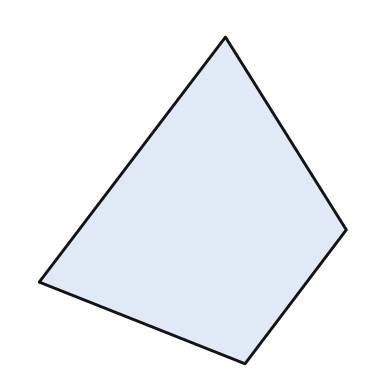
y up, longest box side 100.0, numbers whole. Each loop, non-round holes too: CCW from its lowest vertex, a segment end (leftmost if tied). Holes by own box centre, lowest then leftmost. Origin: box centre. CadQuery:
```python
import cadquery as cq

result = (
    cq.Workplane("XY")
    .moveTo(16.0, -50.0)
    .lineTo(47.0, -9.0)
    .lineTo(10.0, 50.0)
    .lineTo(-47.0, -25.0)
    .close()
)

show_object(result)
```